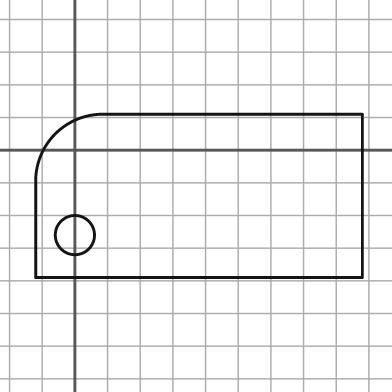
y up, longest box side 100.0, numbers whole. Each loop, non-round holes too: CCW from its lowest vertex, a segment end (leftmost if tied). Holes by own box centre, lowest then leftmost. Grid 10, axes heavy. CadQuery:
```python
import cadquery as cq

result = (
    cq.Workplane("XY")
    .moveTo(-12.0, -39.0)
    .lineTo(88.0, -39.0)
    .lineTo(88.0, 11.0)
    .lineTo(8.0, 11.0)
    .threePointArc((-6.0, 5.0), (-12.0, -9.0))
    .close()
    .moveTo(0.0, -26.0)
    .circle(6.0)
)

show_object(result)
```